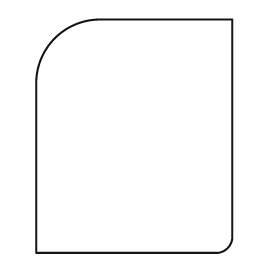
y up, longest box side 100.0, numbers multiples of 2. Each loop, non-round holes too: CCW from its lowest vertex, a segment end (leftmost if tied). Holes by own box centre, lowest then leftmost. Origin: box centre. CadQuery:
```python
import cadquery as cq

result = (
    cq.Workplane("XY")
    .moveTo(-42.0, -50.0)
    .lineTo(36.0, -50.0)
    .threePointArc((40.0, -48.0), (42.0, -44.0))
    .lineTo(42.0, 50.0)
    .lineTo(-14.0, 50.0)
    .threePointArc((-34.0, 42.0), (-42.0, 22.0))
    .close()
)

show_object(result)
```